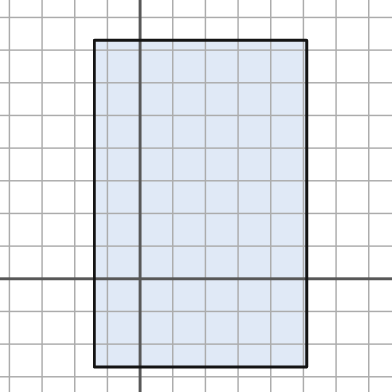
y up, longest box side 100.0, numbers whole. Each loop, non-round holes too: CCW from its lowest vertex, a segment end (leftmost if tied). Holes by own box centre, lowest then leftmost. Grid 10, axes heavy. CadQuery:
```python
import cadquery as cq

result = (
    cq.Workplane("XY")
    .moveTo(-14.0, -27.0)
    .lineTo(51.0, -27.0)
    .lineTo(51.0, 73.0)
    .lineTo(-14.0, 73.0)
    .close()
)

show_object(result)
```